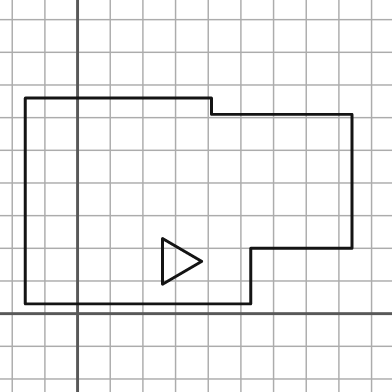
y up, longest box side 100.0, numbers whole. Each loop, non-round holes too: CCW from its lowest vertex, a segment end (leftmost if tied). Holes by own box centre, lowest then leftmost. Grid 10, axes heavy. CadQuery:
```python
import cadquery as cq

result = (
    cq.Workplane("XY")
    .moveTo(-16.0, 3.0)
    .lineTo(53.0, 3.0)
    .lineTo(53.0, 20.0)
    .lineTo(84.0, 20.0)
    .lineTo(84.0, 61.0)
    .lineTo(41.0, 61.0)
    .lineTo(41.0, 66.0)
    .lineTo(-16.0, 66.0)
    .close()
    .moveTo(26.0, 9.0)
    .lineTo(38.0, 16.0)
    .lineTo(26.0, 23.0)
    .close()
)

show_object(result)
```